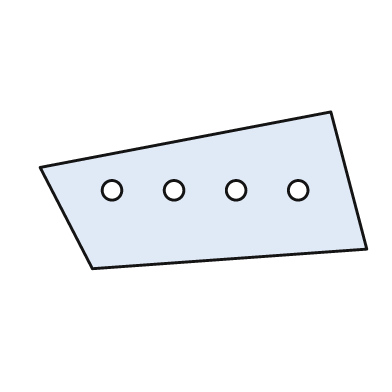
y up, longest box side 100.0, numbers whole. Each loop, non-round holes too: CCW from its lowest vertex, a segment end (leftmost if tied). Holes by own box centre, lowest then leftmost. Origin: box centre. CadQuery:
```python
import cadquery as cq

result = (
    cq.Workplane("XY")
    .moveTo(-34.0, -24.0)
    .lineTo(50.0, -18.0)
    .lineTo(39.0, 24.0)
    .lineTo(-50.0, 7.0)
    .close()
    .moveTo(-28.0, 0.0)
    .circle(3.0)
    .moveTo(-9.0, 0.0)
    .circle(3.0)
    .moveTo(10.0, 0.0)
    .circle(3.0)
    .moveTo(29.0, 0.0)
    .circle(3.0)
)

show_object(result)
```